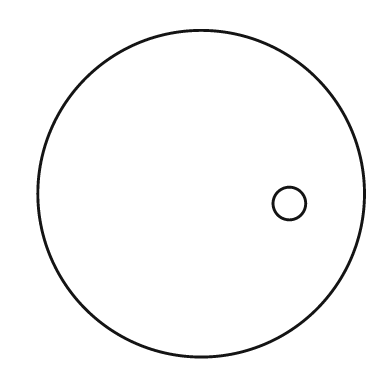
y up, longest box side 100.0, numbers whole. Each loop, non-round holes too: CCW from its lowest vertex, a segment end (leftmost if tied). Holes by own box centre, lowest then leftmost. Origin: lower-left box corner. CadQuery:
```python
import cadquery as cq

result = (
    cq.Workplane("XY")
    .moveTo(50.0, 50.0)
    .circle(50.0)
    .moveTo(77.0, 47.0)
    .circle(5.0)
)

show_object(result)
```